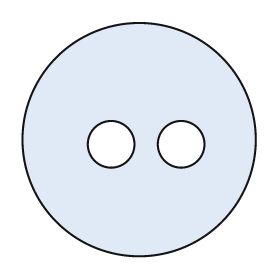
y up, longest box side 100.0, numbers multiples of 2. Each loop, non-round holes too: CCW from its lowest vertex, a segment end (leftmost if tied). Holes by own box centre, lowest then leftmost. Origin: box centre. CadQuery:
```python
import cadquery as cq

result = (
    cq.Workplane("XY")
    .moveTo(0.0, 0.0)
    .circle(50.0)
    .moveTo(-12.0, -2.0)
    .circle(10.0)
    .moveTo(18.0, -2.0)
    .circle(10.0)
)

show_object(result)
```